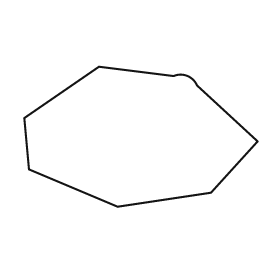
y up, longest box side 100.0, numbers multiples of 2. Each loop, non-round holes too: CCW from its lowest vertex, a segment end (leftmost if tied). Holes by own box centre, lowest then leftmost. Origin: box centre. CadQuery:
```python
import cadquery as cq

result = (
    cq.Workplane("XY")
    .moveTo(-10.0, -30.0)
    .lineTo(30.0, -24.0)
    .lineTo(50.0, -2.0)
    .lineTo(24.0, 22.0)
    .threePointArc((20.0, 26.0), (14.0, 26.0))
    .lineTo(-18.0, 30.0)
    .lineTo(-50.0, 8.0)
    .lineTo(-48.0, -14.0)
    .close()
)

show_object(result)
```